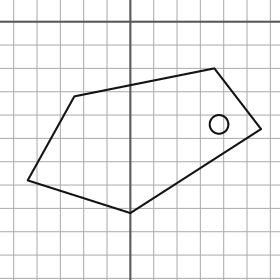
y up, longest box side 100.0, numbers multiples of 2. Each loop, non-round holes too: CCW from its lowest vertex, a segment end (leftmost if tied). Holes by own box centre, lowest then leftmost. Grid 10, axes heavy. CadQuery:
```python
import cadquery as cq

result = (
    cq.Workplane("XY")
    .moveTo(0.0, -82.0)
    .lineTo(56.0, -46.0)
    .lineTo(36.0, -20.0)
    .lineTo(-24.0, -32.0)
    .lineTo(-44.0, -68.0)
    .close()
    .moveTo(38.0, -44.0)
    .circle(4.0)
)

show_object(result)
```